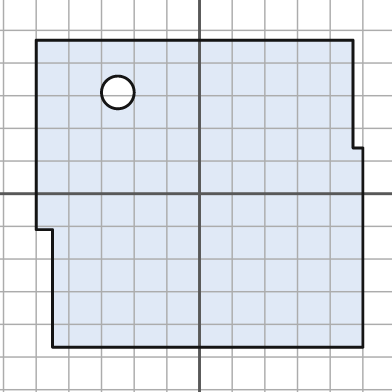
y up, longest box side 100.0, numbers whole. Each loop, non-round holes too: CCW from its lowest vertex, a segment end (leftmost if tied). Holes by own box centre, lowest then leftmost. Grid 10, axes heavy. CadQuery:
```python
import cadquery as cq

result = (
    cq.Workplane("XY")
    .moveTo(-45.0, -47.0)
    .lineTo(50.0, -47.0)
    .lineTo(50.0, 14.0)
    .lineTo(47.0, 14.0)
    .lineTo(47.0, 47.0)
    .lineTo(-50.0, 47.0)
    .lineTo(-50.0, -11.0)
    .lineTo(-45.0, -11.0)
    .close()
    .moveTo(-25.0, 31.0)
    .circle(5.0)
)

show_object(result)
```